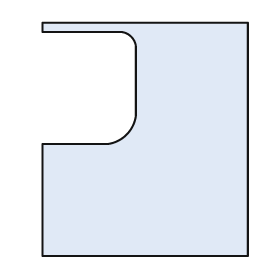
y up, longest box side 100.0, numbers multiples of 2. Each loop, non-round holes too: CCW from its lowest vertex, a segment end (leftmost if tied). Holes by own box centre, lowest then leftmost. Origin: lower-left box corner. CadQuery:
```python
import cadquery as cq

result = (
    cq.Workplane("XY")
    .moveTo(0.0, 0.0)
    .lineTo(88.0, 0.0)
    .lineTo(88.0, 100.0)
    .lineTo(0.0, 100.0)
    .lineTo(0.0, 96.0)
    .lineTo(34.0, 96.0)
    .threePointArc((38.0, 94.0), (40.0, 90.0))
    .lineTo(40.0, 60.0)
    .threePointArc((36.0, 52.0), (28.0, 48.0))
    .lineTo(0.0, 48.0)
    .close()
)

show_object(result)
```